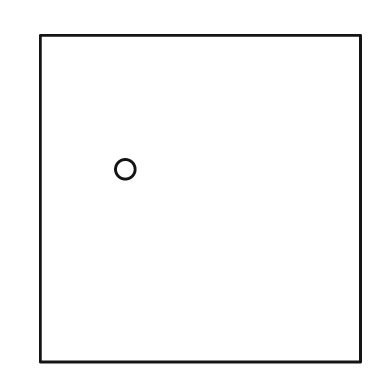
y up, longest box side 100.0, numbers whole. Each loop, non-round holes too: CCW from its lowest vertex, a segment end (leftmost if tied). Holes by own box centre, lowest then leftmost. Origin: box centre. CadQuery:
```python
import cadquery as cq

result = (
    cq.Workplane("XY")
    .moveTo(-49.0, -50.0)
    .lineTo(49.0, -50.0)
    .lineTo(49.0, 50.0)
    .lineTo(-49.0, 50.0)
    .close()
    .moveTo(-23.0, 9.0)
    .circle(3.0)
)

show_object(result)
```